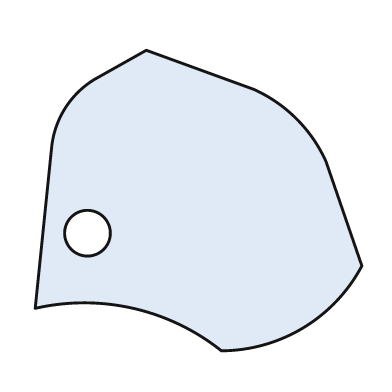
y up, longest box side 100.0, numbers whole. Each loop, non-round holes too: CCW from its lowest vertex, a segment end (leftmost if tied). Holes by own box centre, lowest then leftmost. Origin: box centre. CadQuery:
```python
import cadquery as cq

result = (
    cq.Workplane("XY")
    .moveTo(7.0, -46.0)
    .threePointArc((32.0, -39.0), (50.0, -20.0))
    .lineTo(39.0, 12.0)
    .threePointArc((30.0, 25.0), (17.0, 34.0))
    .lineTo(-16.0, 46.0)
    .lineTo(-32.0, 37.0)
    .threePointArc((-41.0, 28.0), (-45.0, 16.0))
    .lineTo(-50.0, -33.0)
    .threePointArc((-20.0, -33.0), (7.0, -46.0))
    .close()
    .moveTo(-34.0, -10.0)
    .circle(7.0)
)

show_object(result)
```